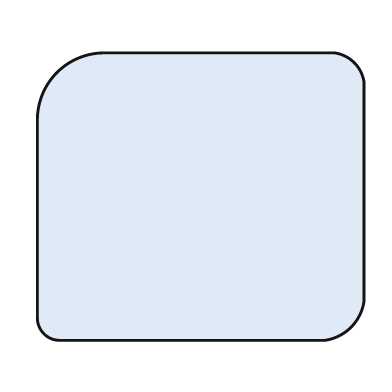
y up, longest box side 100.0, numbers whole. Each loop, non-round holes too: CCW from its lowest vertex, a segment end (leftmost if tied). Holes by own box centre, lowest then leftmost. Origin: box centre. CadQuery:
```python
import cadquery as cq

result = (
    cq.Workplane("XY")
    .moveTo(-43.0, -44.0)
    .lineTo(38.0, -44.0)
    .threePointArc((46.0, -40.0), (50.0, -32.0))
    .lineTo(50.0, 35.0)
    .threePointArc((47.0, 41.0), (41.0, 44.0))
    .lineTo(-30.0, 44.0)
    .threePointArc((-44.0, 38.0), (-50.0, 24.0))
    .lineTo(-50.0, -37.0)
    .threePointArc((-48.0, -42.0), (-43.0, -44.0))
    .close()
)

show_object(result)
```